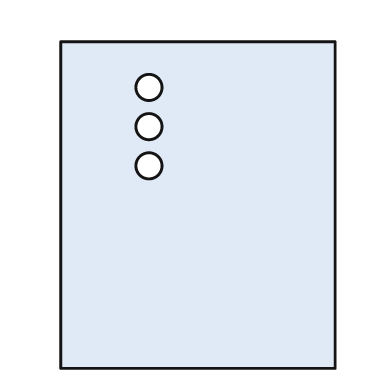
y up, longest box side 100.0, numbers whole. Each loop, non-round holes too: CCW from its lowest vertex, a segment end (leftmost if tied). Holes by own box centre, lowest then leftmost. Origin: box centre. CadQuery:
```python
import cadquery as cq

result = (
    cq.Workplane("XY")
    .moveTo(-42.0, -50.0)
    .lineTo(42.0, -50.0)
    .lineTo(42.0, 50.0)
    .lineTo(-42.0, 50.0)
    .close()
    .moveTo(-15.0, 12.0)
    .circle(4.0)
    .moveTo(-15.0, 24.0)
    .circle(4.0)
    .moveTo(-15.0, 36.0)
    .circle(4.0)
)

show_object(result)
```